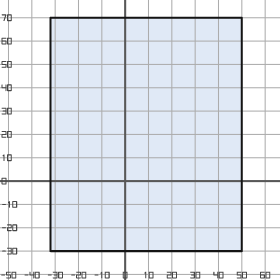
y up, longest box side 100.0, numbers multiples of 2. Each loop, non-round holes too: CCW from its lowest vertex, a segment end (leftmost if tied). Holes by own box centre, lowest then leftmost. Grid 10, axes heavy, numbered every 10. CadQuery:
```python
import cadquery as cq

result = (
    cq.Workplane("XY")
    .moveTo(-32.0, -30.0)
    .lineTo(50.0, -30.0)
    .lineTo(50.0, 70.0)
    .lineTo(-32.0, 70.0)
    .close()
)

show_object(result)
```